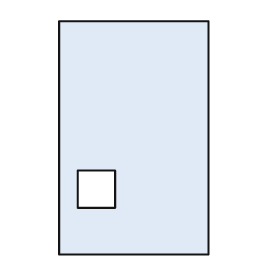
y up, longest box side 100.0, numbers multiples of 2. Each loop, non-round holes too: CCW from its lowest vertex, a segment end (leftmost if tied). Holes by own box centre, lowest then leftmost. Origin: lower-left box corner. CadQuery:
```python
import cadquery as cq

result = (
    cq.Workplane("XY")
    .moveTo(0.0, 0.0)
    .lineTo(64.0, 0.0)
    .lineTo(64.0, 100.0)
    .lineTo(0.0, 100.0)
    .close()
    .moveTo(8.0, 20.0)
    .lineTo(24.0, 20.0)
    .lineTo(24.0, 36.0)
    .lineTo(8.0, 36.0)
    .close()
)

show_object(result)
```